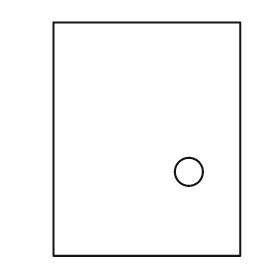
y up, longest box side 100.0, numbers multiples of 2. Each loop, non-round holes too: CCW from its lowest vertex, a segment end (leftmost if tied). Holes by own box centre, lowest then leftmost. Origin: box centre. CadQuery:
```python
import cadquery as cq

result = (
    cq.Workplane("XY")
    .moveTo(-40.0, -50.0)
    .lineTo(40.0, -50.0)
    .lineTo(40.0, 50.0)
    .lineTo(-40.0, 50.0)
    .close()
    .moveTo(18.0, -14.0)
    .circle(6.0)
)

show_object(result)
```